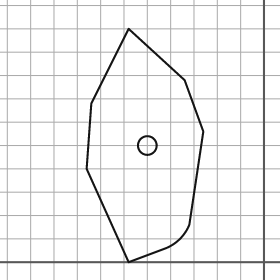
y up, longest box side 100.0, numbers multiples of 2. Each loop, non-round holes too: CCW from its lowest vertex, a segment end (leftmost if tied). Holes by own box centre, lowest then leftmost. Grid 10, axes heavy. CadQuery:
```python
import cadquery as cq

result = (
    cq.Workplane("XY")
    .moveTo(-58.0, 0.0)
    .lineTo(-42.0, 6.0)
    .threePointArc((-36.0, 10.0), (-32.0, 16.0))
    .lineTo(-26.0, 56.0)
    .lineTo(-34.0, 78.0)
    .lineTo(-58.0, 100.0)
    .lineTo(-74.0, 68.0)
    .lineTo(-76.0, 40.0)
    .close()
    .moveTo(-50.0, 50.0)
    .circle(4.0)
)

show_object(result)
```